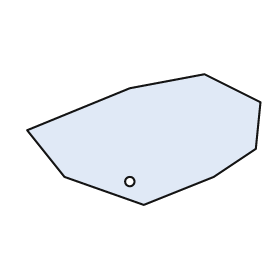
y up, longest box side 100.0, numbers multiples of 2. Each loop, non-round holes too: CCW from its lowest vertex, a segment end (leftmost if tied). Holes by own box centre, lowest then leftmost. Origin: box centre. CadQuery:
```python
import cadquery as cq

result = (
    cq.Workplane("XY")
    .moveTo(0.0, -28.0)
    .lineTo(30.0, -16.0)
    .lineTo(48.0, -4.0)
    .lineTo(50.0, 16.0)
    .lineTo(26.0, 28.0)
    .lineTo(-6.0, 22.0)
    .lineTo(-50.0, 4.0)
    .lineTo(-34.0, -16.0)
    .close()
    .moveTo(-6.0, -18.0)
    .circle(2.0)
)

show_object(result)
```